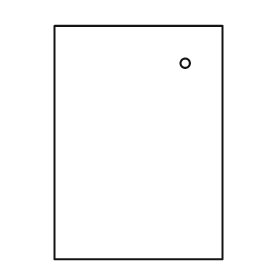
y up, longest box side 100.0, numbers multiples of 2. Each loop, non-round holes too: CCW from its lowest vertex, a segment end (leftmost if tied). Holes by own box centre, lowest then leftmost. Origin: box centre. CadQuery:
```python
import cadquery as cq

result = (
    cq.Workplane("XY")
    .moveTo(-36.0, -50.0)
    .lineTo(36.0, -50.0)
    .lineTo(36.0, 50.0)
    .lineTo(-36.0, 50.0)
    .close()
    .moveTo(20.0, 34.0)
    .circle(2.0)
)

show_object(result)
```